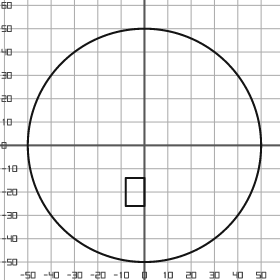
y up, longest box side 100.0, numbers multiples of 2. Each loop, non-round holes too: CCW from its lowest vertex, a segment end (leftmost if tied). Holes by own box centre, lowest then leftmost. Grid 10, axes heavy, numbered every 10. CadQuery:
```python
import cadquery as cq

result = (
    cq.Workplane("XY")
    .moveTo(0.0, 0.0)
    .circle(50.0)
    .moveTo(-8.0, -26.0)
    .lineTo(0.0, -26.0)
    .lineTo(0.0, -14.0)
    .lineTo(-8.0, -14.0)
    .close()
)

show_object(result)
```